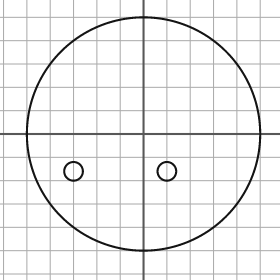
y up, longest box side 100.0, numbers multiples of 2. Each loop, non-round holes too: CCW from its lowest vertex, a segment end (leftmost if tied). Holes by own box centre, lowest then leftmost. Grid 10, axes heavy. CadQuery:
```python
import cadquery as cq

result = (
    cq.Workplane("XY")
    .moveTo(0.0, 0.0)
    .circle(50.0)
    .moveTo(-30.0, -16.0)
    .circle(4.0)
    .moveTo(10.0, -16.0)
    .circle(4.0)
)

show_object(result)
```